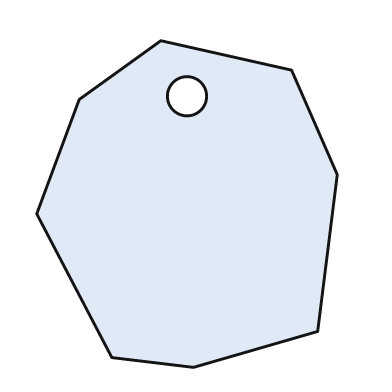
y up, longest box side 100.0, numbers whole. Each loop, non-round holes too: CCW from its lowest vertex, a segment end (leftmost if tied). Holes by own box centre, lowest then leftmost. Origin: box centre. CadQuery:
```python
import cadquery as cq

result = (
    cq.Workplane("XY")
    .moveTo(2.0, -50.0)
    .lineTo(40.0, -39.0)
    .lineTo(46.0, 9.0)
    .lineTo(32.0, 41.0)
    .lineTo(-8.0, 50.0)
    .lineTo(-33.0, 32.0)
    .lineTo(-46.0, -3.0)
    .lineTo(-23.0, -47.0)
    .close()
    .moveTo(0.0, 33.0)
    .circle(6.0)
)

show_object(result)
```